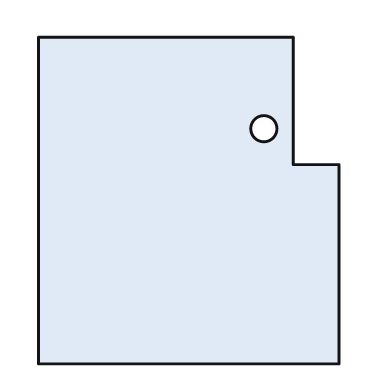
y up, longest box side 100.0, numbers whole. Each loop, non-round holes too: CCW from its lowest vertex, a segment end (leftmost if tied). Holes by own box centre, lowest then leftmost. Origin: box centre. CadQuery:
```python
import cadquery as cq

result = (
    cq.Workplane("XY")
    .moveTo(-46.0, -50.0)
    .lineTo(46.0, -50.0)
    .lineTo(46.0, 11.0)
    .lineTo(32.0, 11.0)
    .lineTo(32.0, 50.0)
    .lineTo(-46.0, 50.0)
    .close()
    .moveTo(23.0, 22.0)
    .circle(4.0)
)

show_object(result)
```